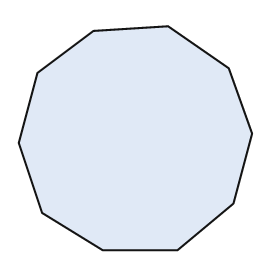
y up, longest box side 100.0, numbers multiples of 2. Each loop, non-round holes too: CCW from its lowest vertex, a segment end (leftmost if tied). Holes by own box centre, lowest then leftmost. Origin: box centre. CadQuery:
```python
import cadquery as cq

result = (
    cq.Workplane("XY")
    .moveTo(-14.0, -48.0)
    .lineTo(18.0, -48.0)
    .lineTo(42.0, -28.0)
    .lineTo(50.0, 2.0)
    .lineTo(40.0, 30.0)
    .lineTo(14.0, 48.0)
    .lineTo(-18.0, 46.0)
    .lineTo(-42.0, 28.0)
    .lineTo(-50.0, -2.0)
    .lineTo(-40.0, -32.0)
    .close()
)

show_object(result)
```